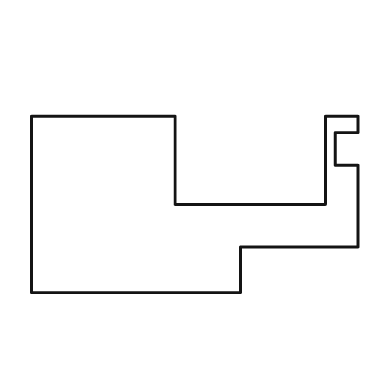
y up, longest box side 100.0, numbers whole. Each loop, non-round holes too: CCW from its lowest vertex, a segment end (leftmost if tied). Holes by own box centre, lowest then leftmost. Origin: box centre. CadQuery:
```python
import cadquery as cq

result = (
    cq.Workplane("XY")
    .moveTo(-50.0, -27.0)
    .lineTo(14.0, -27.0)
    .lineTo(14.0, -13.0)
    .lineTo(50.0, -13.0)
    .lineTo(50.0, 12.0)
    .lineTo(43.0, 12.0)
    .lineTo(43.0, 22.0)
    .lineTo(50.0, 22.0)
    .lineTo(50.0, 27.0)
    .lineTo(40.0, 27.0)
    .lineTo(40.0, 0.0)
    .lineTo(-6.0, 0.0)
    .lineTo(-6.0, 27.0)
    .lineTo(-50.0, 27.0)
    .close()
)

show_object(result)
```